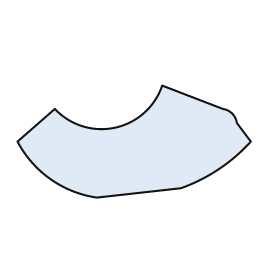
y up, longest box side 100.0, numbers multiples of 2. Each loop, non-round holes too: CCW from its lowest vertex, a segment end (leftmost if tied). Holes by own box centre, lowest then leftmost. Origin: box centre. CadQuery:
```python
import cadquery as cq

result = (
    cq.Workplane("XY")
    .moveTo(-16.0, -24.0)
    .lineTo(20.0, -20.0)
    .threePointArc((36.0, -12.0), (50.0, 0.0))
    .lineTo(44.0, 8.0)
    .threePointArc((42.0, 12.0), (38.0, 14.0))
    .lineTo(12.0, 24.0)
    .threePointArc((-8.0, 6.0), (-34.0, 14.0))
    .lineTo(-50.0, 0.0)
    .threePointArc((-36.0, -16.0), (-16.0, -24.0))
    .close()
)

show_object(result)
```